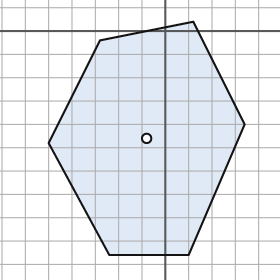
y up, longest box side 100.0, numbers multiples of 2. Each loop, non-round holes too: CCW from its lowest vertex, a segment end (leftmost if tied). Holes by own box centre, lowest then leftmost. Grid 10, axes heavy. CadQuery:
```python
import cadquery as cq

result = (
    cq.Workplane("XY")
    .moveTo(-24.0, -96.0)
    .lineTo(10.0, -96.0)
    .lineTo(34.0, -40.0)
    .lineTo(12.0, 4.0)
    .lineTo(-28.0, -4.0)
    .lineTo(-50.0, -48.0)
    .close()
    .moveTo(-8.0, -46.0)
    .circle(2.0)
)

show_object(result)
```